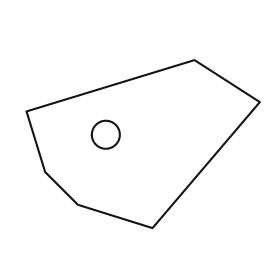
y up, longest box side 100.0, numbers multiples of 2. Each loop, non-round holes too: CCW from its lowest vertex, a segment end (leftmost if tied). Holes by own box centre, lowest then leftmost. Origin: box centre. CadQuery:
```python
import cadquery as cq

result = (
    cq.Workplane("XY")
    .moveTo(4.0, -36.0)
    .lineTo(50.0, 18.0)
    .lineTo(22.0, 36.0)
    .lineTo(-50.0, 14.0)
    .lineTo(-42.0, -12.0)
    .lineTo(-28.0, -26.0)
    .close()
    .moveTo(-16.0, 4.0)
    .circle(6.0)
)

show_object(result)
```